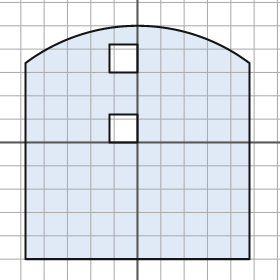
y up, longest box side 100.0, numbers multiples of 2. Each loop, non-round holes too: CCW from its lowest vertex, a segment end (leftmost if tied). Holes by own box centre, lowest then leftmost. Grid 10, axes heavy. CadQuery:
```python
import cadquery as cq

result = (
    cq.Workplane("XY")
    .moveTo(-48.0, -50.0)
    .lineTo(48.0, -50.0)
    .lineTo(48.0, 34.0)
    .threePointArc((0.0, 50.0), (-48.0, 34.0))
    .close()
    .moveTo(-12.0, 0.0)
    .lineTo(0.0, 0.0)
    .lineTo(0.0, 12.0)
    .lineTo(-12.0, 12.0)
    .close()
    .moveTo(-12.0, 30.0)
    .lineTo(0.0, 30.0)
    .lineTo(0.0, 42.0)
    .lineTo(-12.0, 42.0)
    .close()
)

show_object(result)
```